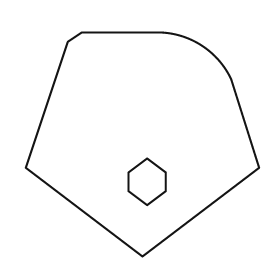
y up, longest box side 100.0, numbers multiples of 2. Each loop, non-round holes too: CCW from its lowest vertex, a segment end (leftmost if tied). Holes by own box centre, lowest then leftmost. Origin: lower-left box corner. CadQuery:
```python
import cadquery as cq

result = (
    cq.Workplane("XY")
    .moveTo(50.0, 0.0)
    .lineTo(100.0, 38.0)
    .lineTo(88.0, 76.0)
    .threePointArc((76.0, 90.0), (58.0, 96.0))
    .lineTo(24.0, 96.0)
    .lineTo(18.0, 92.0)
    .lineTo(0.0, 38.0)
    .close()
    .moveTo(52.0, 22.0)
    .lineTo(60.0, 28.0)
    .lineTo(60.0, 36.0)
    .lineTo(52.0, 42.0)
    .lineTo(44.0, 36.0)
    .lineTo(44.0, 28.0)
    .close()
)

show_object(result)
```